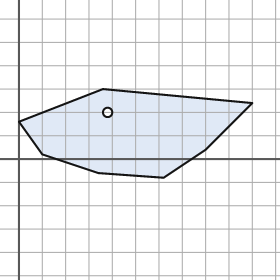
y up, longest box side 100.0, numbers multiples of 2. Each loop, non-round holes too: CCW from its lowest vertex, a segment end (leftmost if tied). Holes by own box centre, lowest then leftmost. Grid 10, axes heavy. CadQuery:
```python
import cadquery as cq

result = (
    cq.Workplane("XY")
    .moveTo(62.0, -8.0)
    .lineTo(80.0, 4.0)
    .lineTo(100.0, 24.0)
    .lineTo(36.0, 30.0)
    .lineTo(0.0, 16.0)
    .lineTo(10.0, 2.0)
    .lineTo(34.0, -6.0)
    .close()
    .moveTo(38.0, 20.0)
    .circle(2.0)
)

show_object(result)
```